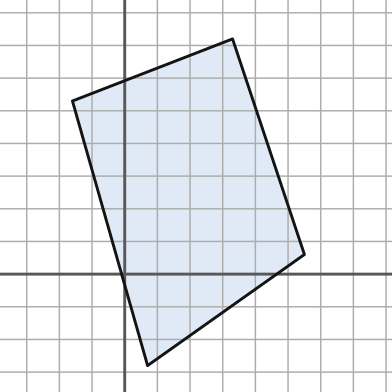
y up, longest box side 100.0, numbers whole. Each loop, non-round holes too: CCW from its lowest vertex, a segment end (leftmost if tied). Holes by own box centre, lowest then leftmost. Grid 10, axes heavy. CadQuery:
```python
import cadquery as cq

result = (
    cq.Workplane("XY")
    .moveTo(7.0, -28.0)
    .lineTo(55.0, 6.0)
    .lineTo(33.0, 72.0)
    .lineTo(-16.0, 53.0)
    .close()
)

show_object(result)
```